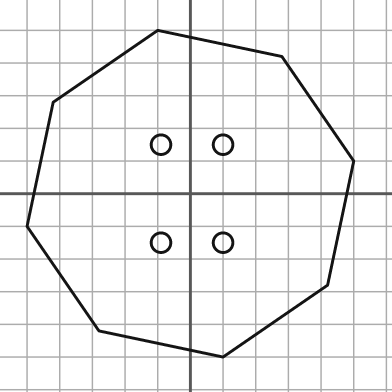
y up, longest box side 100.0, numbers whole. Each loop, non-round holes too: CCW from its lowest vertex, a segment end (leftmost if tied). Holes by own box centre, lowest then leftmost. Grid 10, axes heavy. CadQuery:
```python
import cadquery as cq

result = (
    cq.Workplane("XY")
    .moveTo(10.0, -50.0)
    .lineTo(42.0, -28.0)
    .lineTo(50.0, 10.0)
    .lineTo(28.0, 42.0)
    .lineTo(-10.0, 50.0)
    .lineTo(-42.0, 28.0)
    .lineTo(-50.0, -10.0)
    .lineTo(-28.0, -42.0)
    .close()
    .moveTo(-9.0, -15.0)
    .circle(3.0)
    .moveTo(10.0, -15.0)
    .circle(3.0)
    .moveTo(-9.0, 15.0)
    .circle(3.0)
    .moveTo(10.0, 15.0)
    .circle(3.0)
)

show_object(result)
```